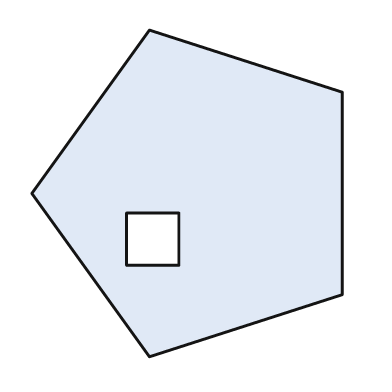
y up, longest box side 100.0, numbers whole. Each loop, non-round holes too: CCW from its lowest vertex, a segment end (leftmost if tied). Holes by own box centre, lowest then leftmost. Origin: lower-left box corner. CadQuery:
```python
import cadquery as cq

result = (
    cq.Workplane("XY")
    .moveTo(36.0, 0.0)
    .lineTo(95.0, 19.0)
    .lineTo(95.0, 81.0)
    .lineTo(36.0, 100.0)
    .lineTo(0.0, 50.0)
    .close()
    .moveTo(29.0, 28.0)
    .lineTo(45.0, 28.0)
    .lineTo(45.0, 44.0)
    .lineTo(29.0, 44.0)
    .close()
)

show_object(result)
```